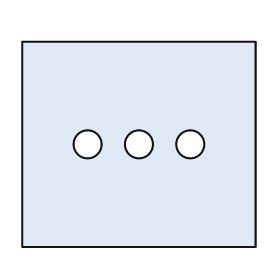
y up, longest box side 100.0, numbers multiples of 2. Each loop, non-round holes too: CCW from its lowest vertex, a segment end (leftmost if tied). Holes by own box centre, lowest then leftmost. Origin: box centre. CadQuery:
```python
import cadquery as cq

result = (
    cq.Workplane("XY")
    .moveTo(-50.0, -44.0)
    .lineTo(50.0, -44.0)
    .lineTo(50.0, 44.0)
    .lineTo(-50.0, 44.0)
    .close()
    .moveTo(-22.0, 0.0)
    .circle(6.0)
    .moveTo(0.0, 0.0)
    .circle(6.0)
    .moveTo(22.0, 0.0)
    .circle(6.0)
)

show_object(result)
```